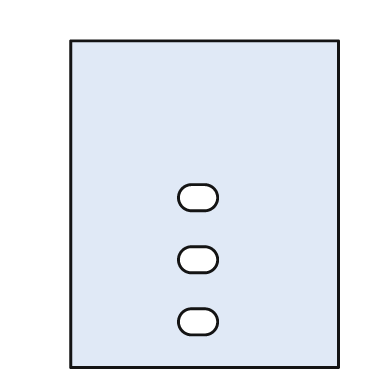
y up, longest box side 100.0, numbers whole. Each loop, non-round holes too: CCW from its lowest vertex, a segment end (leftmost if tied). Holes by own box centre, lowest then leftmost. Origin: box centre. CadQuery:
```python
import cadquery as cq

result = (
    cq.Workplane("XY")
    .moveTo(-41.0, -50.0)
    .lineTo(41.0, -50.0)
    .lineTo(41.0, 50.0)
    .lineTo(-41.0, 50.0)
    .close()
    .moveTo(-4.0, -40.0)
    .lineTo(0.0, -40.0)
    .threePointArc((4.0, -36.0), (0.0, -32.0))
    .lineTo(-4.0, -32.0)
    .threePointArc((-8.0, -36.0), (-4.0, -40.0))
    .close()
    .moveTo(-4.0, -21.0)
    .lineTo(0.0, -21.0)
    .threePointArc((4.0, -17.0), (0.0, -13.0))
    .lineTo(-4.0, -13.0)
    .threePointArc((-8.0, -17.0), (-4.0, -21.0))
    .close()
    .moveTo(-4.0, -2.0)
    .lineTo(0.0, -2.0)
    .threePointArc((4.0, 2.0), (0.0, 6.0))
    .lineTo(-4.0, 6.0)
    .threePointArc((-8.0, 2.0), (-4.0, -2.0))
    .close()
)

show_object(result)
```